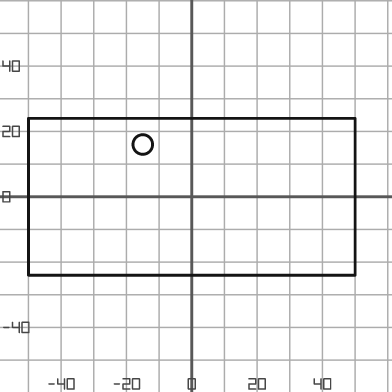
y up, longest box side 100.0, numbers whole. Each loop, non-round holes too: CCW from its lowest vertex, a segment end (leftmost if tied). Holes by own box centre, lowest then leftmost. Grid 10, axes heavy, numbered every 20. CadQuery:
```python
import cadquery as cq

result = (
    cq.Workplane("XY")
    .moveTo(-50.0, -24.0)
    .lineTo(50.0, -24.0)
    .lineTo(50.0, 24.0)
    .lineTo(-50.0, 24.0)
    .close()
    .moveTo(-15.0, 16.0)
    .circle(3.0)
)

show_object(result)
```